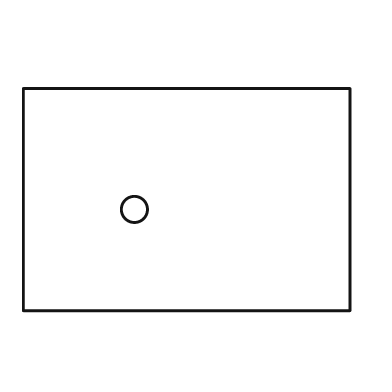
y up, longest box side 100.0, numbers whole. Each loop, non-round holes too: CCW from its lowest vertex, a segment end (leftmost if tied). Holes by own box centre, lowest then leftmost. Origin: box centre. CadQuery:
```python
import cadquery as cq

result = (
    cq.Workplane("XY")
    .moveTo(-50.0, -34.0)
    .lineTo(50.0, -34.0)
    .lineTo(50.0, 34.0)
    .lineTo(-50.0, 34.0)
    .close()
    .moveTo(-16.0, -3.0)
    .circle(4.0)
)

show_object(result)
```